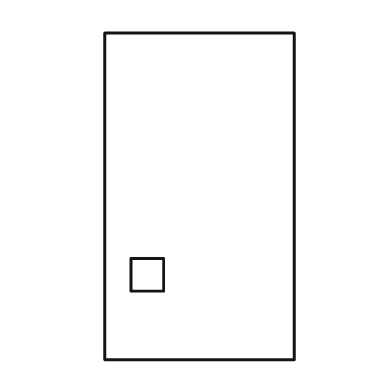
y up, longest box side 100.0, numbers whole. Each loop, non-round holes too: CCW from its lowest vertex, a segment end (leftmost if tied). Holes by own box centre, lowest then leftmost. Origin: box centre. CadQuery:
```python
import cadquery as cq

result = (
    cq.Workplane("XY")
    .moveTo(-29.0, -50.0)
    .lineTo(29.0, -50.0)
    .lineTo(29.0, 50.0)
    .lineTo(-29.0, 50.0)
    .close()
    .moveTo(-21.0, -29.0)
    .lineTo(-11.0, -29.0)
    .lineTo(-11.0, -19.0)
    .lineTo(-21.0, -19.0)
    .close()
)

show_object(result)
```